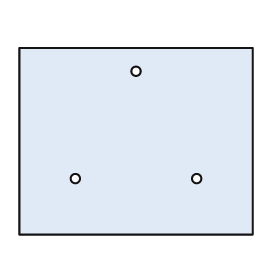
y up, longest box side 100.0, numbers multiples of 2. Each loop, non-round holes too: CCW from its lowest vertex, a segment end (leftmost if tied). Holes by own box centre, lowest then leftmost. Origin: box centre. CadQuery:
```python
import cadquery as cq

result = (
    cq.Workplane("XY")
    .moveTo(-50.0, -40.0)
    .lineTo(50.0, -40.0)
    .lineTo(50.0, 40.0)
    .lineTo(-50.0, 40.0)
    .close()
    .moveTo(-26.0, -16.0)
    .circle(2.0)
    .moveTo(26.0, -16.0)
    .circle(2.0)
    .moveTo(0.0, 30.0)
    .circle(2.0)
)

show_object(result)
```